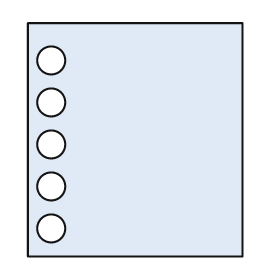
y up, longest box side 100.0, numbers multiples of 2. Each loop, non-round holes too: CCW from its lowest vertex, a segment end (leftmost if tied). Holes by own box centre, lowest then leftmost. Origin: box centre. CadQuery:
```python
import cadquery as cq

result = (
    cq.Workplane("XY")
    .moveTo(-46.0, -50.0)
    .lineTo(46.0, -50.0)
    .lineTo(46.0, 50.0)
    .lineTo(-46.0, 50.0)
    .close()
    .moveTo(-36.0, -38.0)
    .circle(6.0)
    .moveTo(-36.0, -20.0)
    .circle(6.0)
    .moveTo(-36.0, -2.0)
    .circle(6.0)
    .moveTo(-36.0, 16.0)
    .circle(6.0)
    .moveTo(-36.0, 34.0)
    .circle(6.0)
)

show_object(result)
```